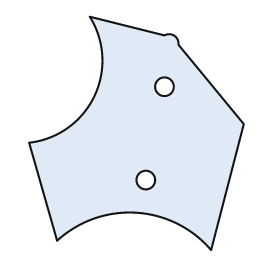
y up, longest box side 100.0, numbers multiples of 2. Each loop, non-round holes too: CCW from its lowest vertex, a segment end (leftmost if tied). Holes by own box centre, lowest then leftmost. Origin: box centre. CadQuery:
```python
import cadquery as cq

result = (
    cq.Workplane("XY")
    .moveTo(32.0, -50.0)
    .lineTo(46.0, 4.0)
    .lineTo(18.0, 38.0)
    .threePointArc((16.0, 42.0), (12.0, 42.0))
    .lineTo(-20.0, 50.0)
    .threePointArc((-18.0, 16.0), (-46.0, -4.0))
    .lineTo(-34.0, -46.0)
    .threePointArc((0.0, -34.0), (32.0, -50.0))
    .close()
    .moveTo(4.0, -20.0)
    .circle(4.0)
    .moveTo(12.0, 20.0)
    .circle(4.0)
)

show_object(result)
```